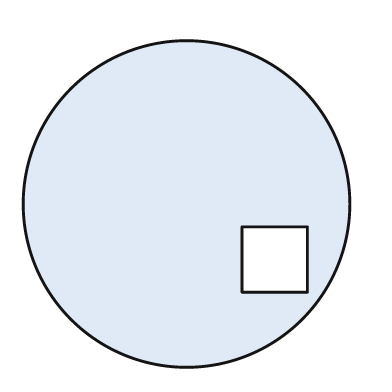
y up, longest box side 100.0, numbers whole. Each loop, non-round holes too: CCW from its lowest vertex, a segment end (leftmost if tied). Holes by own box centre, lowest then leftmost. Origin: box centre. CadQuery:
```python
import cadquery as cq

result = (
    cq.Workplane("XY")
    .moveTo(0.0, 0.0)
    .circle(50.0)
    .moveTo(17.0, -27.0)
    .lineTo(37.0, -27.0)
    .lineTo(37.0, -7.0)
    .lineTo(17.0, -7.0)
    .close()
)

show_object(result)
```